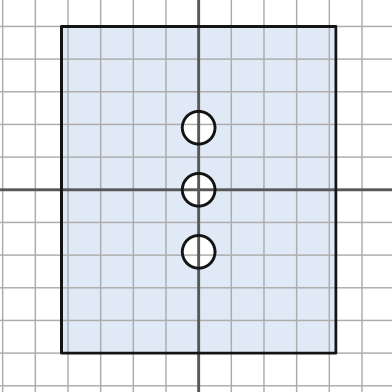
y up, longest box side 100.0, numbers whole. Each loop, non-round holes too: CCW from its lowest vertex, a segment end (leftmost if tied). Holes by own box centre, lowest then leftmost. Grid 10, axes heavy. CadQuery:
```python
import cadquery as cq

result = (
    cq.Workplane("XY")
    .moveTo(-42.0, -50.0)
    .lineTo(42.0, -50.0)
    .lineTo(42.0, 50.0)
    .lineTo(-42.0, 50.0)
    .close()
    .moveTo(0.0, -19.0)
    .circle(5.0)
    .moveTo(0.0, 0.0)
    .circle(5.0)
    .moveTo(0.0, 19.0)
    .circle(5.0)
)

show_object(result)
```